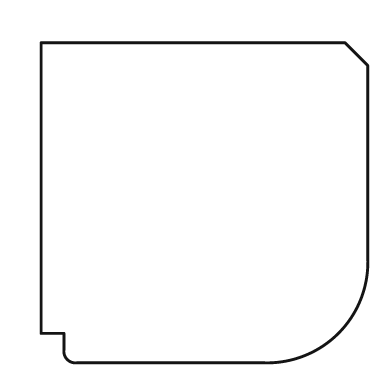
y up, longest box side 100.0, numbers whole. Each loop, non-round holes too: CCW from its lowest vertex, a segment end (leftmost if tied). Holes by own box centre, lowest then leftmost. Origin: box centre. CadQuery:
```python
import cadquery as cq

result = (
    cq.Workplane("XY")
    .moveTo(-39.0, -49.0)
    .lineTo(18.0, -49.0)
    .threePointArc((41.0, -40.0), (50.0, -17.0))
    .lineTo(50.0, 42.0)
    .lineTo(43.0, 49.0)
    .lineTo(-50.0, 49.0)
    .lineTo(-50.0, -40.0)
    .lineTo(-43.0, -40.0)
    .lineTo(-43.0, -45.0)
    .threePointArc((-42.0, -48.0), (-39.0, -49.0))
    .close()
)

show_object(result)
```